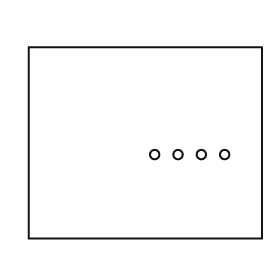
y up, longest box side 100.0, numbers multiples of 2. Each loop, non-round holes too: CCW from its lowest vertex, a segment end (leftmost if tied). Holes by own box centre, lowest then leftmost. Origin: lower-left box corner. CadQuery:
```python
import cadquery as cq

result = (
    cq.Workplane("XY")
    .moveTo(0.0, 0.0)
    .lineTo(100.0, 0.0)
    .lineTo(100.0, 82.0)
    .lineTo(0.0, 82.0)
    .close()
    .moveTo(54.0, 36.0)
    .circle(2.0)
    .moveTo(64.0, 36.0)
    .circle(2.0)
    .moveTo(74.0, 36.0)
    .circle(2.0)
    .moveTo(84.0, 36.0)
    .circle(2.0)
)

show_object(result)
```